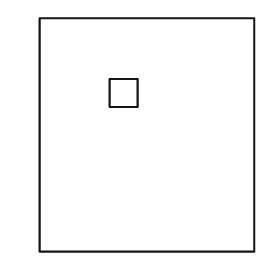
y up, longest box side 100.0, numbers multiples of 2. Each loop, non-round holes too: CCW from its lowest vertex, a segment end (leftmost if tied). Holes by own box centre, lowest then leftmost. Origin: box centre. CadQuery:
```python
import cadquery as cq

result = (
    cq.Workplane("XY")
    .moveTo(-46.0, -50.0)
    .lineTo(46.0, -50.0)
    .lineTo(46.0, 50.0)
    .lineTo(-46.0, 50.0)
    .close()
    .moveTo(-16.0, 12.0)
    .lineTo(-4.0, 12.0)
    .lineTo(-4.0, 24.0)
    .lineTo(-16.0, 24.0)
    .close()
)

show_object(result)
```